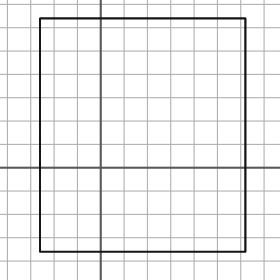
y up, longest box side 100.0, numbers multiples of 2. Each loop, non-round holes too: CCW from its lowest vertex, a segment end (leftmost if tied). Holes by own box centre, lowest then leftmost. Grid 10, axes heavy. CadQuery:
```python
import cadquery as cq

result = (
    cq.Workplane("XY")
    .moveTo(-26.0, -36.0)
    .lineTo(62.0, -36.0)
    .lineTo(62.0, 64.0)
    .lineTo(-26.0, 64.0)
    .close()
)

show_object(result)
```